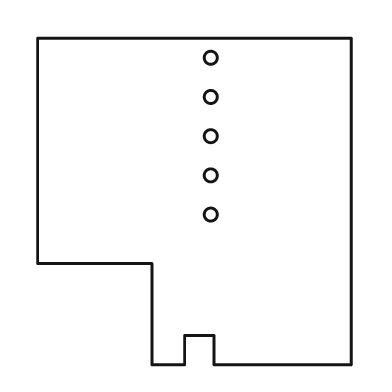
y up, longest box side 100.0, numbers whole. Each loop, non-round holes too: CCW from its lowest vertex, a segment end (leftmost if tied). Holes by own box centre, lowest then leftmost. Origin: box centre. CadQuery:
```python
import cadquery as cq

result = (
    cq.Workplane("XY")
    .moveTo(-13.0, -50.0)
    .lineTo(-3.0, -50.0)
    .lineTo(-3.0, -41.0)
    .lineTo(6.0, -41.0)
    .lineTo(6.0, -50.0)
    .lineTo(48.0, -50.0)
    .lineTo(48.0, 50.0)
    .lineTo(-48.0, 50.0)
    .lineTo(-48.0, -19.0)
    .lineTo(-13.0, -19.0)
    .close()
    .moveTo(5.0, -4.0)
    .circle(2.0)
    .moveTo(5.0, 8.0)
    .circle(2.0)
    .moveTo(5.0, 20.0)
    .circle(2.0)
    .moveTo(5.0, 32.0)
    .circle(2.0)
    .moveTo(5.0, 44.0)
    .circle(2.0)
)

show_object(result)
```